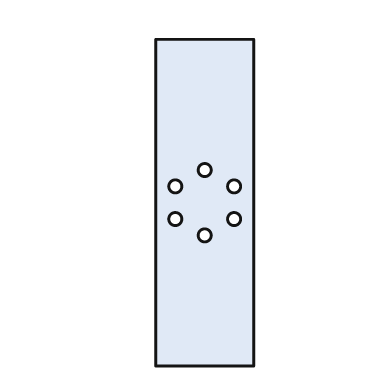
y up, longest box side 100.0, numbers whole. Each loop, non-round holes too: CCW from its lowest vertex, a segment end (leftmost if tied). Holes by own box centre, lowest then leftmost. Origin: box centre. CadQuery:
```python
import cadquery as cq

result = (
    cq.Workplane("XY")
    .moveTo(-15.0, -50.0)
    .lineTo(15.0, -50.0)
    .lineTo(15.0, 50.0)
    .lineTo(-15.0, 50.0)
    .close()
    .moveTo(0.0, -10.0)
    .circle(2.0)
    .moveTo(-9.0, -5.0)
    .circle(2.0)
    .moveTo(9.0, -5.0)
    .circle(2.0)
    .moveTo(-9.0, 5.0)
    .circle(2.0)
    .moveTo(9.0, 5.0)
    .circle(2.0)
    .moveTo(0.0, 10.0)
    .circle(2.0)
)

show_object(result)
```